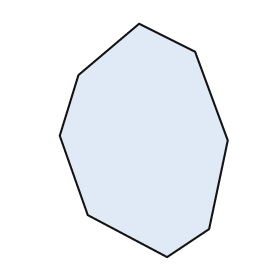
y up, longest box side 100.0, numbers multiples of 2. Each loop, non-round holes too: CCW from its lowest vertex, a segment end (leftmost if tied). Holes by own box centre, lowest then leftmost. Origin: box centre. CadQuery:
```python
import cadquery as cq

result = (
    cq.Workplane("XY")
    .moveTo(10.0, -50.0)
    .lineTo(28.0, -38.0)
    .lineTo(36.0, 0.0)
    .lineTo(22.0, 38.0)
    .lineTo(-2.0, 50.0)
    .lineTo(-28.0, 28.0)
    .lineTo(-36.0, 2.0)
    .lineTo(-24.0, -32.0)
    .close()
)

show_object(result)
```